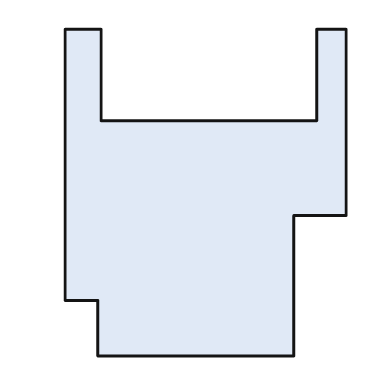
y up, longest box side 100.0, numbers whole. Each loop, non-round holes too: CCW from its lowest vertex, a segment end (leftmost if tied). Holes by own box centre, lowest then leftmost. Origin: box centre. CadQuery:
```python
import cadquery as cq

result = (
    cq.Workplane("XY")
    .moveTo(-33.0, -50.0)
    .lineTo(27.0, -50.0)
    .lineTo(27.0, -7.0)
    .lineTo(43.0, -7.0)
    .lineTo(43.0, 50.0)
    .lineTo(34.0, 50.0)
    .lineTo(34.0, 22.0)
    .lineTo(-32.0, 22.0)
    .lineTo(-32.0, 50.0)
    .lineTo(-43.0, 50.0)
    .lineTo(-43.0, -33.0)
    .lineTo(-33.0, -33.0)
    .close()
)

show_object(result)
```